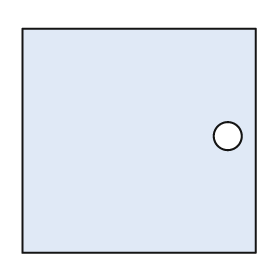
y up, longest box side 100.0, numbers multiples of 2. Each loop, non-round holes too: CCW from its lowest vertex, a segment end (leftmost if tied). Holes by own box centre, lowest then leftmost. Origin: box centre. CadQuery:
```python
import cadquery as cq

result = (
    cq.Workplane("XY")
    .moveTo(-50.0, -48.0)
    .lineTo(50.0, -48.0)
    .lineTo(50.0, 48.0)
    .lineTo(-50.0, 48.0)
    .close()
    .moveTo(38.0, 2.0)
    .circle(6.0)
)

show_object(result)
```